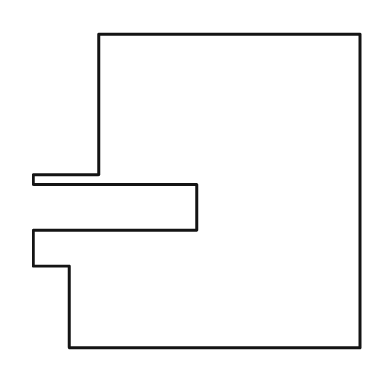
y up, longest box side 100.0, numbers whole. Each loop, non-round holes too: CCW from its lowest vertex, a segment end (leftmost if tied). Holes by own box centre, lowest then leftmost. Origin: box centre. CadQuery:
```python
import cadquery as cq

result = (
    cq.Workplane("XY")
    .moveTo(-39.0, -48.0)
    .lineTo(50.0, -48.0)
    .lineTo(50.0, 48.0)
    .lineTo(-30.0, 48.0)
    .lineTo(-30.0, 5.0)
    .lineTo(-50.0, 5.0)
    .lineTo(-50.0, 2.0)
    .lineTo(0.0, 2.0)
    .lineTo(0.0, -12.0)
    .lineTo(-50.0, -12.0)
    .lineTo(-50.0, -23.0)
    .lineTo(-39.0, -23.0)
    .close()
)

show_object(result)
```